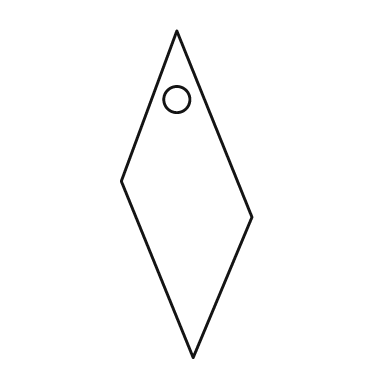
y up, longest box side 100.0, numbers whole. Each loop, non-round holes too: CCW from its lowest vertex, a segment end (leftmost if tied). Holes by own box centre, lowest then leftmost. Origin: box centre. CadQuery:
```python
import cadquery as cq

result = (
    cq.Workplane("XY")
    .moveTo(2.0, -50.0)
    .lineTo(20.0, -7.0)
    .lineTo(-3.0, 50.0)
    .lineTo(-20.0, 4.0)
    .close()
    .moveTo(-3.0, 29.0)
    .circle(4.0)
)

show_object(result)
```